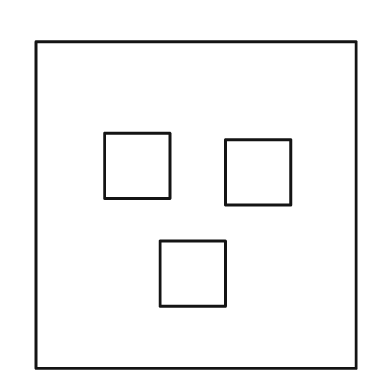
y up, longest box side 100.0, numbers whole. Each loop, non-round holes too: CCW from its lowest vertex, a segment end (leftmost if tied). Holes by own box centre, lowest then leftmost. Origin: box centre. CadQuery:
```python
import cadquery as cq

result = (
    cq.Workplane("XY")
    .moveTo(-49.0, -50.0)
    .lineTo(49.0, -50.0)
    .lineTo(49.0, 50.0)
    .lineTo(-49.0, 50.0)
    .close()
    .moveTo(-11.0, -31.0)
    .lineTo(9.0, -31.0)
    .lineTo(9.0, -11.0)
    .lineTo(-11.0, -11.0)
    .close()
    .moveTo(9.0, 0.0)
    .lineTo(29.0, 0.0)
    .lineTo(29.0, 20.0)
    .lineTo(9.0, 20.0)
    .close()
    .moveTo(-28.0, 2.0)
    .lineTo(-8.0, 2.0)
    .lineTo(-8.0, 22.0)
    .lineTo(-28.0, 22.0)
    .close()
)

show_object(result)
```